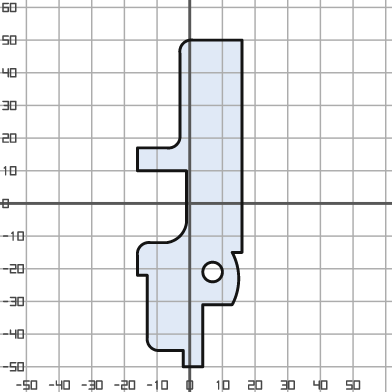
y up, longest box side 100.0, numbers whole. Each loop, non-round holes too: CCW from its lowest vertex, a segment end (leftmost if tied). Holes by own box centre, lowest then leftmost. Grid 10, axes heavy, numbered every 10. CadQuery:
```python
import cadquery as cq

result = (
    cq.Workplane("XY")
    .moveTo(-2.0, -50.0)
    .lineTo(4.0, -50.0)
    .lineTo(4.0, -31.0)
    .lineTo(13.0, -31.0)
    .threePointArc((15.0, -23.0), (13.0, -15.0))
    .lineTo(16.0, -15.0)
    .lineTo(16.0, 50.0)
    .lineTo(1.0, 50.0)
    .threePointArc((-2.0, 49.0), (-3.0, 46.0))
    .lineTo(-3.0, 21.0)
    .threePointArc((-4.0, 18.0), (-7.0, 17.0))
    .lineTo(-16.0, 17.0)
    .lineTo(-16.0, 10.0)
    .lineTo(-1.0, 10.0)
    .lineTo(-1.0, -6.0)
    .threePointArc((-3.0, -10.0), (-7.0, -12.0))
    .lineTo(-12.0, -12.0)
    .threePointArc((-15.0, -13.0), (-16.0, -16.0))
    .lineTo(-16.0, -22.0)
    .lineTo(-13.0, -22.0)
    .lineTo(-13.0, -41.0)
    .threePointArc((-12.0, -44.0), (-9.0, -45.0))
    .lineTo(-2.0, -45.0)
    .close()
    .moveTo(7.0, -21.0)
    .circle(3.0)
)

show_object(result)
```